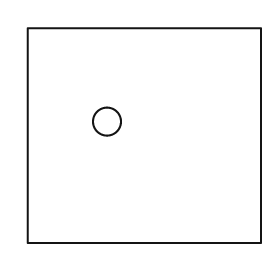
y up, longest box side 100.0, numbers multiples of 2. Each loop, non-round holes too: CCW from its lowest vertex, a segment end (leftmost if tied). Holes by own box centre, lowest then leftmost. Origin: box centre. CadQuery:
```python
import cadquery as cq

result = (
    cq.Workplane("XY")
    .moveTo(-50.0, -46.0)
    .lineTo(50.0, -46.0)
    .lineTo(50.0, 46.0)
    .lineTo(-50.0, 46.0)
    .close()
    .moveTo(-16.0, 6.0)
    .circle(6.0)
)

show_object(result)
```